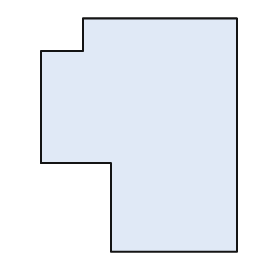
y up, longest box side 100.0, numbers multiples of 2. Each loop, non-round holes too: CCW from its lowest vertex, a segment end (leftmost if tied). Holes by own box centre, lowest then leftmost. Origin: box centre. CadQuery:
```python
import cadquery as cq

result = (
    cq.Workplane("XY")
    .moveTo(-12.0, -50.0)
    .lineTo(42.0, -50.0)
    .lineTo(42.0, 50.0)
    .lineTo(-24.0, 50.0)
    .lineTo(-24.0, 36.0)
    .lineTo(-42.0, 36.0)
    .lineTo(-42.0, -12.0)
    .lineTo(-12.0, -12.0)
    .close()
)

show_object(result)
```